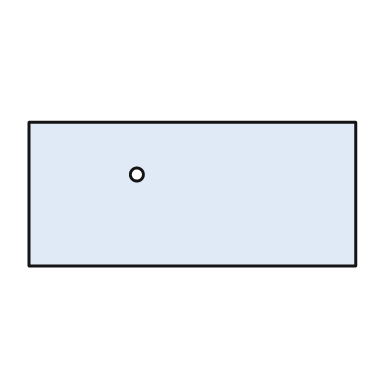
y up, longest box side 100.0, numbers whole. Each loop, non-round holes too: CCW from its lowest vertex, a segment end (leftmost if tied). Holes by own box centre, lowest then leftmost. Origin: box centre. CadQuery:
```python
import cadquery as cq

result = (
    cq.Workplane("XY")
    .moveTo(-50.0, -22.0)
    .lineTo(50.0, -22.0)
    .lineTo(50.0, 22.0)
    .lineTo(-50.0, 22.0)
    .close()
    .moveTo(-17.0, 6.0)
    .circle(2.0)
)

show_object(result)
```